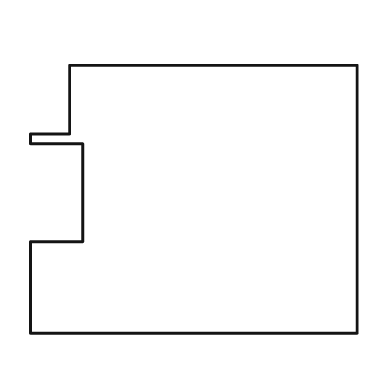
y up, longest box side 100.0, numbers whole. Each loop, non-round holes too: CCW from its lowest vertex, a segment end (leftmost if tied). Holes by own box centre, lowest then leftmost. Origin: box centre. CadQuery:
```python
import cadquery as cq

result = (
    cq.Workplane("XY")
    .moveTo(-50.0, -41.0)
    .lineTo(50.0, -41.0)
    .lineTo(50.0, 41.0)
    .lineTo(-38.0, 41.0)
    .lineTo(-38.0, 20.0)
    .lineTo(-50.0, 20.0)
    .lineTo(-50.0, 17.0)
    .lineTo(-34.0, 17.0)
    .lineTo(-34.0, -13.0)
    .lineTo(-50.0, -13.0)
    .close()
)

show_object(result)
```